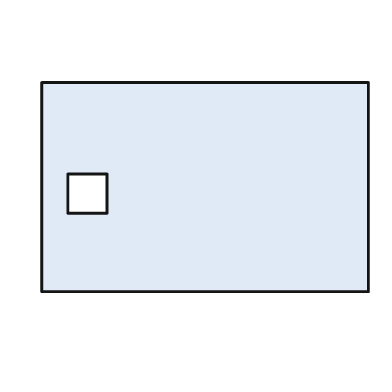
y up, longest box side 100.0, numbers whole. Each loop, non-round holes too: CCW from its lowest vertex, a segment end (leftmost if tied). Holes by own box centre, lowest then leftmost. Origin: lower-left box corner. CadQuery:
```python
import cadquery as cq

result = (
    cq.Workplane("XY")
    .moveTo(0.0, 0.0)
    .lineTo(100.0, 0.0)
    .lineTo(100.0, 64.0)
    .lineTo(0.0, 64.0)
    .close()
    .moveTo(8.0, 24.0)
    .lineTo(20.0, 24.0)
    .lineTo(20.0, 36.0)
    .lineTo(8.0, 36.0)
    .close()
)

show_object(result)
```